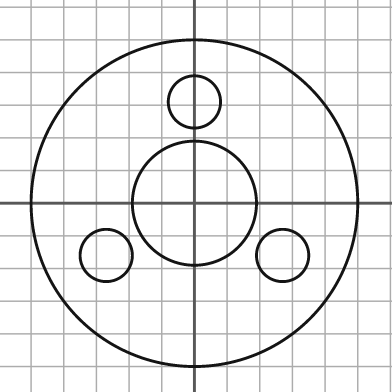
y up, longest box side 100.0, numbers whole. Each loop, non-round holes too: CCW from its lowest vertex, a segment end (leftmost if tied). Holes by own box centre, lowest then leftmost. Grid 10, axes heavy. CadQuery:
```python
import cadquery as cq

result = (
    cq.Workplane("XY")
    .moveTo(0.0, 0.0)
    .circle(50.0)
    .moveTo(-27.0, -16.0)
    .circle(8.0)
    .moveTo(27.0, -16.0)
    .circle(8.0)
    .moveTo(0.0, 0.0)
    .circle(19.0)
    .moveTo(0.0, 31.0)
    .circle(8.0)
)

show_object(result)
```